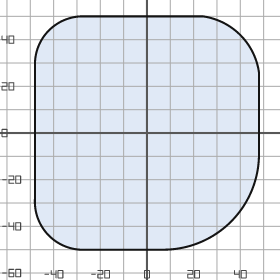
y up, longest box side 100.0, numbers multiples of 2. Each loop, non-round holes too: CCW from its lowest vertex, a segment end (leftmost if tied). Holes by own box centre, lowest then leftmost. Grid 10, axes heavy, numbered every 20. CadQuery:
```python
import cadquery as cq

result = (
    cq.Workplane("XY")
    .moveTo(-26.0, -50.0)
    .lineTo(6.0, -50.0)
    .threePointArc((36.0, -38.0), (48.0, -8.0))
    .lineTo(48.0, 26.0)
    .threePointArc((40.0, 42.0), (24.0, 50.0))
    .lineTo(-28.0, 50.0)
    .threePointArc((-42.0, 44.0), (-48.0, 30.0))
    .lineTo(-48.0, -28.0)
    .threePointArc((-42.0, -44.0), (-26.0, -50.0))
    .close()
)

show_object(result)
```